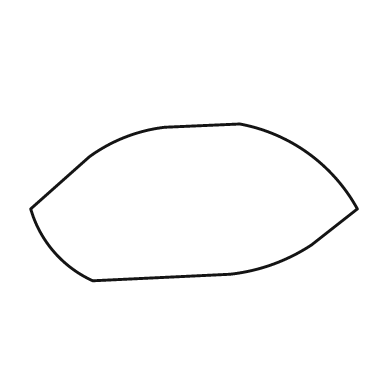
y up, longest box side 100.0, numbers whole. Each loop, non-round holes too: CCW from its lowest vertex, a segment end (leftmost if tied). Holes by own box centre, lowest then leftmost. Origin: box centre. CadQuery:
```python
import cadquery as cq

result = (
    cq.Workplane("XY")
    .moveTo(-31.0, -24.0)
    .lineTo(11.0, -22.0)
    .threePointArc((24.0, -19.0), (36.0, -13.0))
    .lineTo(50.0, -2.0)
    .threePointArc((35.0, 15.0), (14.0, 24.0))
    .lineTo(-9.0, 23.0)
    .threePointArc((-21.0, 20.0), (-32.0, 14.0))
    .lineTo(-50.0, -2.0)
    .threePointArc((-43.0, -15.0), (-31.0, -24.0))
    .close()
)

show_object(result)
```